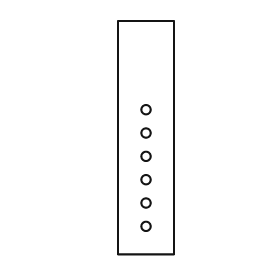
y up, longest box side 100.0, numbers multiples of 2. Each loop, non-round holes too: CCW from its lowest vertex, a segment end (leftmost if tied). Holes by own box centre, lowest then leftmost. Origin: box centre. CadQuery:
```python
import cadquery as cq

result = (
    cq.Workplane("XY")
    .moveTo(-12.0, -50.0)
    .lineTo(12.0, -50.0)
    .lineTo(12.0, 50.0)
    .lineTo(-12.0, 50.0)
    .close()
    .moveTo(0.0, -38.0)
    .circle(2.0)
    .moveTo(0.0, -28.0)
    .circle(2.0)
    .moveTo(0.0, -18.0)
    .circle(2.0)
    .moveTo(0.0, -8.0)
    .circle(2.0)
    .moveTo(0.0, 2.0)
    .circle(2.0)
    .moveTo(0.0, 12.0)
    .circle(2.0)
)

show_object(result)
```